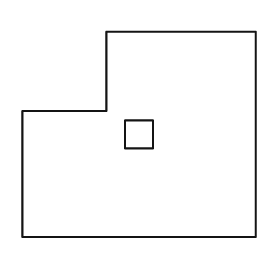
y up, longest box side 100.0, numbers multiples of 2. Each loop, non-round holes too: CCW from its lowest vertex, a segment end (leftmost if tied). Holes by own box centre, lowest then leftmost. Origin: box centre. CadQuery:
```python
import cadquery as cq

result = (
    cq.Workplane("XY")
    .moveTo(-50.0, -44.0)
    .lineTo(50.0, -44.0)
    .lineTo(50.0, 44.0)
    .lineTo(-14.0, 44.0)
    .lineTo(-14.0, 10.0)
    .lineTo(-50.0, 10.0)
    .close()
    .moveTo(-6.0, -6.0)
    .lineTo(6.0, -6.0)
    .lineTo(6.0, 6.0)
    .lineTo(-6.0, 6.0)
    .close()
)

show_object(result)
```